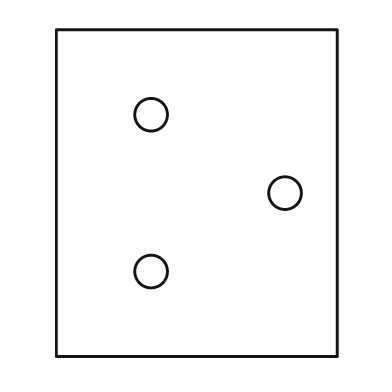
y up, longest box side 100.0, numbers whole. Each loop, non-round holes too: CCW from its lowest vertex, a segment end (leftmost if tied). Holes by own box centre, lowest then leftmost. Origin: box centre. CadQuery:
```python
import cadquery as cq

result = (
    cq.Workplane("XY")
    .moveTo(-43.0, -50.0)
    .lineTo(43.0, -50.0)
    .lineTo(43.0, 50.0)
    .lineTo(-43.0, 50.0)
    .close()
    .moveTo(-14.0, -24.0)
    .circle(5.0)
    .moveTo(27.0, 0.0)
    .circle(5.0)
    .moveTo(-14.0, 24.0)
    .circle(5.0)
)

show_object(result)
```